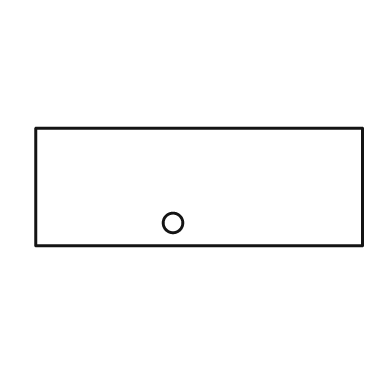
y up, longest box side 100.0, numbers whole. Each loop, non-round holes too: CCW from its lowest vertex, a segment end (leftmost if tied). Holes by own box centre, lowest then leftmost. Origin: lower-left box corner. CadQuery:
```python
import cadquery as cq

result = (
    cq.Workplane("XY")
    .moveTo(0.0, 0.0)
    .lineTo(100.0, 0.0)
    .lineTo(100.0, 36.0)
    .lineTo(0.0, 36.0)
    .close()
    .moveTo(42.0, 7.0)
    .circle(3.0)
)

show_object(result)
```